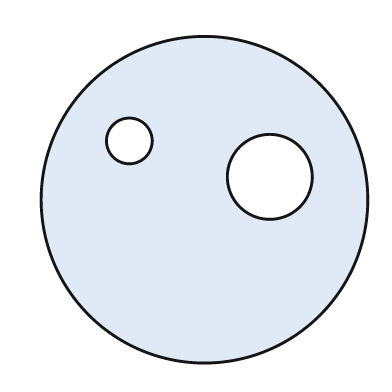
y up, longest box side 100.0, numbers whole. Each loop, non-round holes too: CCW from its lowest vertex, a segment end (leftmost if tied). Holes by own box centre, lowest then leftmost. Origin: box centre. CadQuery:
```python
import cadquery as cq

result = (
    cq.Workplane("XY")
    .moveTo(0.0, 0.0)
    .circle(50.0)
    .moveTo(20.0, 7.0)
    .circle(13.0)
    .moveTo(-23.0, 18.0)
    .circle(7.0)
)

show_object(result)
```